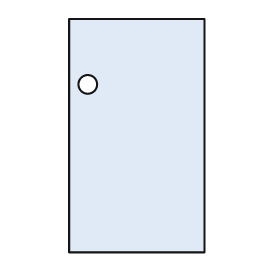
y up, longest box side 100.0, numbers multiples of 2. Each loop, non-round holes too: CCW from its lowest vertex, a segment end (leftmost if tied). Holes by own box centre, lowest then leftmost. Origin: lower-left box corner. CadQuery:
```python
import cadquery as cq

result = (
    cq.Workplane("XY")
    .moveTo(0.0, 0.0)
    .lineTo(58.0, 0.0)
    .lineTo(58.0, 100.0)
    .lineTo(0.0, 100.0)
    .close()
    .moveTo(8.0, 72.0)
    .circle(4.0)
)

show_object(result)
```